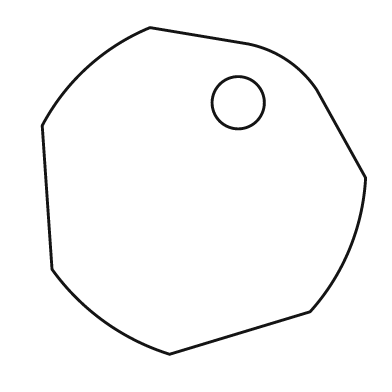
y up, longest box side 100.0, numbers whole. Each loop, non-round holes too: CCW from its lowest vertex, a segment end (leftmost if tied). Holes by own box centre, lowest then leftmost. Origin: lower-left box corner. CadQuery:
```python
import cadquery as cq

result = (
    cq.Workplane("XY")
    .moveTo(39.0, 0.0)
    .lineTo(82.0, 13.0)
    .threePointArc((94.0, 32.0), (99.0, 54.0))
    .lineTo(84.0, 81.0)
    .threePointArc((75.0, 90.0), (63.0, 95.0))
    .lineTo(33.0, 100.0)
    .threePointArc((14.0, 88.0), (0.0, 70.0))
    .lineTo(3.0, 26.0)
    .threePointArc((19.0, 10.0), (39.0, 0.0))
    .close()
    .moveTo(60.0, 77.0)
    .circle(8.0)
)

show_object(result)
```